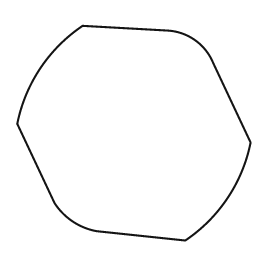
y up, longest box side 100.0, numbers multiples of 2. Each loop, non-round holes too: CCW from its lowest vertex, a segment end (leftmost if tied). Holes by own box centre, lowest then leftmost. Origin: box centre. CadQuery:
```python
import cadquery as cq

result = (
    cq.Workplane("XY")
    .moveTo(22.0, -46.0)
    .threePointArc((40.0, -28.0), (50.0, -4.0))
    .lineTo(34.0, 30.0)
    .threePointArc((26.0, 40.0), (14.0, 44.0))
    .lineTo(-22.0, 46.0)
    .threePointArc((-40.0, 28.0), (-50.0, 4.0))
    .lineTo(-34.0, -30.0)
    .threePointArc((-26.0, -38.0), (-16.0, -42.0))
    .close()
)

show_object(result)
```